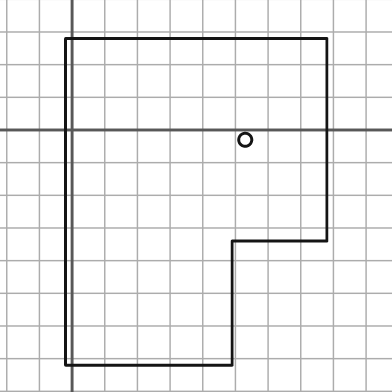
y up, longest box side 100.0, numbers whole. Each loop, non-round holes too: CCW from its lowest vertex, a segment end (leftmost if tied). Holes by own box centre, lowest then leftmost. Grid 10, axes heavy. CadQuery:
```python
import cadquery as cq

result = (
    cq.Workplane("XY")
    .moveTo(-2.0, -72.0)
    .lineTo(49.0, -72.0)
    .lineTo(49.0, -34.0)
    .lineTo(78.0, -34.0)
    .lineTo(78.0, 28.0)
    .lineTo(-2.0, 28.0)
    .close()
    .moveTo(53.0, -3.0)
    .circle(2.0)
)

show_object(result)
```